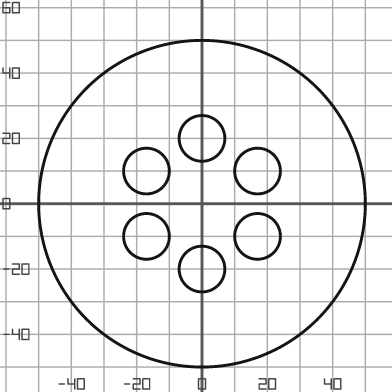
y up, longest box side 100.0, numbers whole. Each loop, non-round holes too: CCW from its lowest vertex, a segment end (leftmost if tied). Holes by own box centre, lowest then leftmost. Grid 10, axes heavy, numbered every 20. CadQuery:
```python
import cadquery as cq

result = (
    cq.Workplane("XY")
    .moveTo(0.0, 0.0)
    .circle(50.0)
    .moveTo(0.0, -20.0)
    .circle(7.0)
    .moveTo(-17.0, -10.0)
    .circle(7.0)
    .moveTo(17.0, -10.0)
    .circle(7.0)
    .moveTo(-17.0, 10.0)
    .circle(7.0)
    .moveTo(17.0, 10.0)
    .circle(7.0)
    .moveTo(0.0, 20.0)
    .circle(7.0)
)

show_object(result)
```